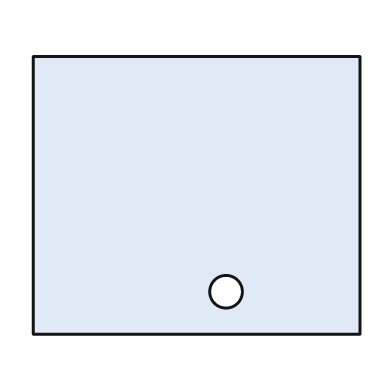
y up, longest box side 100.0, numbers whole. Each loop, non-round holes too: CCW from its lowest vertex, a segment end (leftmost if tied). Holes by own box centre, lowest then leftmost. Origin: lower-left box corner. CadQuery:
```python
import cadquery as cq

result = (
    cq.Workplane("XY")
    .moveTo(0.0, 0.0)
    .lineTo(100.0, 0.0)
    .lineTo(100.0, 85.0)
    .lineTo(0.0, 85.0)
    .close()
    .moveTo(59.0, 13.0)
    .circle(5.0)
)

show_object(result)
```